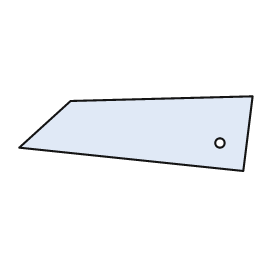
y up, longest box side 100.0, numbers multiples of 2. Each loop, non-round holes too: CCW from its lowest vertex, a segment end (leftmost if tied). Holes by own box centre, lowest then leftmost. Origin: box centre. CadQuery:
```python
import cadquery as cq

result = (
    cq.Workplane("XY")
    .moveTo(46.0, -16.0)
    .lineTo(50.0, 16.0)
    .lineTo(-28.0, 14.0)
    .lineTo(-50.0, -6.0)
    .close()
    .moveTo(36.0, -4.0)
    .circle(2.0)
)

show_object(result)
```